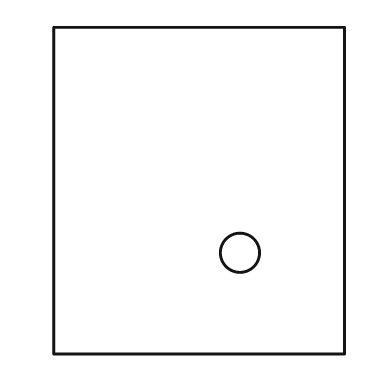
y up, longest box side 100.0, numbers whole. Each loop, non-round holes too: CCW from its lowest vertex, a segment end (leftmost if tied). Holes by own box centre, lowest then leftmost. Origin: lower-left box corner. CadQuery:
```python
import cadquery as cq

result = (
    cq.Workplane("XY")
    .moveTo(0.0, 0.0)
    .lineTo(89.0, 0.0)
    .lineTo(89.0, 100.0)
    .lineTo(0.0, 100.0)
    .close()
    .moveTo(57.0, 31.0)
    .circle(6.0)
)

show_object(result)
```